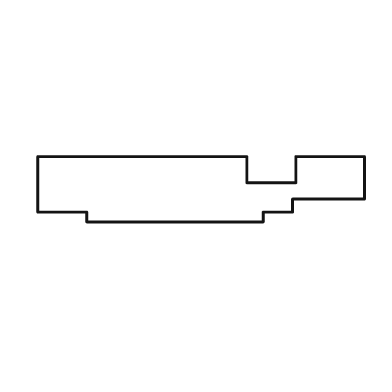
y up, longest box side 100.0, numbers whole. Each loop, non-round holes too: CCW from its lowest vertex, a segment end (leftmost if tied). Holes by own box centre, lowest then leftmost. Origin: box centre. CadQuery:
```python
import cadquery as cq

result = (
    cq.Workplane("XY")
    .moveTo(-35.0, -10.0)
    .lineTo(19.0, -10.0)
    .lineTo(19.0, -7.0)
    .lineTo(28.0, -7.0)
    .lineTo(28.0, -3.0)
    .lineTo(50.0, -3.0)
    .lineTo(50.0, 10.0)
    .lineTo(29.0, 10.0)
    .lineTo(29.0, 2.0)
    .lineTo(14.0, 2.0)
    .lineTo(14.0, 10.0)
    .lineTo(-50.0, 10.0)
    .lineTo(-50.0, -7.0)
    .lineTo(-35.0, -7.0)
    .close()
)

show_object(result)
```